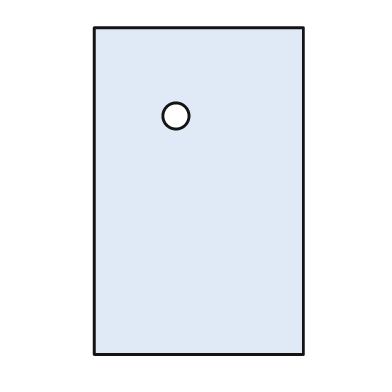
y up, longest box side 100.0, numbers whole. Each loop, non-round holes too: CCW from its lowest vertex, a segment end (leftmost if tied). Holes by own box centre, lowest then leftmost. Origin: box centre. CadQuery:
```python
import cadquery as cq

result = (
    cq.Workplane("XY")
    .moveTo(-32.0, -50.0)
    .lineTo(32.0, -50.0)
    .lineTo(32.0, 50.0)
    .lineTo(-32.0, 50.0)
    .close()
    .moveTo(-7.0, 23.0)
    .circle(4.0)
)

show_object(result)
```